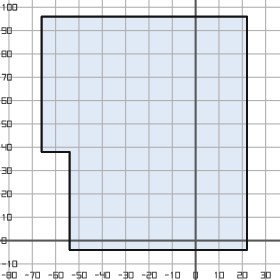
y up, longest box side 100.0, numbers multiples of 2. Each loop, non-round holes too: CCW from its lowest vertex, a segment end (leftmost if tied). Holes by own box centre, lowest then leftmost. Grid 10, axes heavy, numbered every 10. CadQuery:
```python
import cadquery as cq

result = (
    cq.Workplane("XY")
    .moveTo(-54.0, -4.0)
    .lineTo(22.0, -4.0)
    .lineTo(22.0, 96.0)
    .lineTo(-66.0, 96.0)
    .lineTo(-66.0, 38.0)
    .lineTo(-54.0, 38.0)
    .close()
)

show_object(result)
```